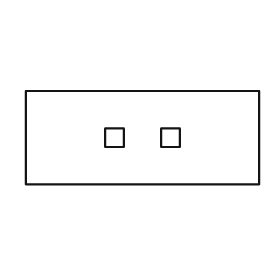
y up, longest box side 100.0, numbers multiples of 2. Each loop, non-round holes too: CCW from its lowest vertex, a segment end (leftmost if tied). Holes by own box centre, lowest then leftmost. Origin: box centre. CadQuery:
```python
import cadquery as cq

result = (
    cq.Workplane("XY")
    .moveTo(-50.0, -20.0)
    .lineTo(50.0, -20.0)
    .lineTo(50.0, 20.0)
    .lineTo(-50.0, 20.0)
    .close()
    .moveTo(-16.0, -4.0)
    .lineTo(-8.0, -4.0)
    .lineTo(-8.0, 4.0)
    .lineTo(-16.0, 4.0)
    .close()
    .moveTo(8.0, -4.0)
    .lineTo(16.0, -4.0)
    .lineTo(16.0, 4.0)
    .lineTo(8.0, 4.0)
    .close()
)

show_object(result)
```